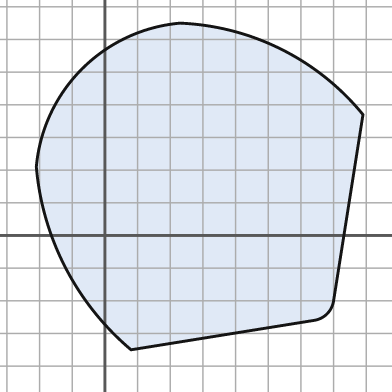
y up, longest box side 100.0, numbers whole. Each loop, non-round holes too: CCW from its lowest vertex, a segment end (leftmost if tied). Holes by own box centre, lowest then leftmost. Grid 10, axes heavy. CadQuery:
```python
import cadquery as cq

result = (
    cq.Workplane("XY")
    .moveTo(8.0, -35.0)
    .lineTo(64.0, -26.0)
    .threePointArc((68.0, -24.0), (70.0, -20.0))
    .lineTo(79.0, 37.0)
    .threePointArc((54.0, 57.0), (23.0, 65.0))
    .threePointArc((-7.0, 51.0), (-21.0, 21.0))
    .threePointArc((-12.0, -10.0), (8.0, -35.0))
    .close()
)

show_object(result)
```